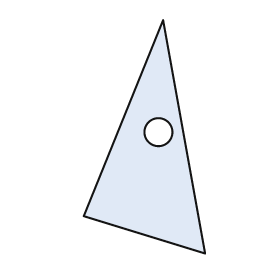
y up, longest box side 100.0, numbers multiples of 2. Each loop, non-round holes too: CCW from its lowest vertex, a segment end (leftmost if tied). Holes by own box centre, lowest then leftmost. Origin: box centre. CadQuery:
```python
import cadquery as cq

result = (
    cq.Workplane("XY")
    .moveTo(26.0, -50.0)
    .lineTo(8.0, 50.0)
    .lineTo(-26.0, -34.0)
    .close()
    .moveTo(6.0, 2.0)
    .circle(6.0)
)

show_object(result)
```